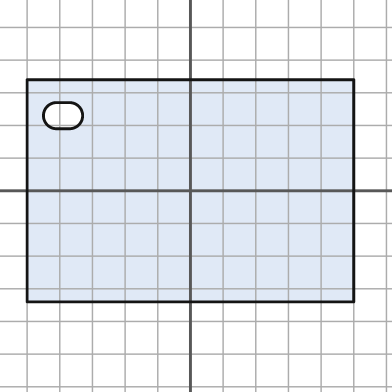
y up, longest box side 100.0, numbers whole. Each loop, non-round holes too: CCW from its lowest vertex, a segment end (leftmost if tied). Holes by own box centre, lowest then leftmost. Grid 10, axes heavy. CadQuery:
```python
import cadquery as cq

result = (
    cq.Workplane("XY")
    .moveTo(-50.0, -34.0)
    .lineTo(50.0, -34.0)
    .lineTo(50.0, 34.0)
    .lineTo(-50.0, 34.0)
    .close()
    .moveTo(-41.0, 19.0)
    .lineTo(-37.0, 19.0)
    .threePointArc((-33.0, 23.0), (-37.0, 27.0))
    .lineTo(-41.0, 27.0)
    .threePointArc((-45.0, 23.0), (-41.0, 19.0))
    .close()
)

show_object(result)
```